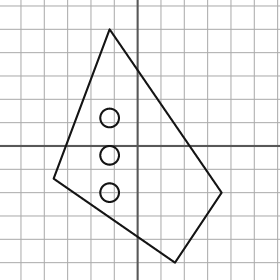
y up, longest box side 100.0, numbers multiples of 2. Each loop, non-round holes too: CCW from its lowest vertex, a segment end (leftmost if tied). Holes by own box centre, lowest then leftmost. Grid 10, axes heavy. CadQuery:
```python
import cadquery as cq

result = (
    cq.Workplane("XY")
    .moveTo(16.0, -50.0)
    .lineTo(36.0, -20.0)
    .lineTo(-12.0, 50.0)
    .lineTo(-36.0, -14.0)
    .close()
    .moveTo(-12.0, -20.0)
    .circle(4.0)
    .moveTo(-12.0, -4.0)
    .circle(4.0)
    .moveTo(-12.0, 12.0)
    .circle(4.0)
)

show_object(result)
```